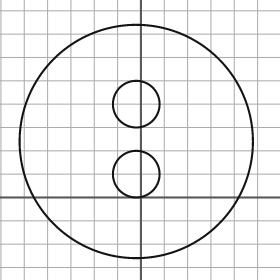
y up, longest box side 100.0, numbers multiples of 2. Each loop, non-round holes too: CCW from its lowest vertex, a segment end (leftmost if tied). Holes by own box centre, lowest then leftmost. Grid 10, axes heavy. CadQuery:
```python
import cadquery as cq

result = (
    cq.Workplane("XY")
    .moveTo(-2.0, 24.0)
    .circle(50.0)
    .moveTo(-2.0, 10.0)
    .circle(10.0)
    .moveTo(-2.0, 40.0)
    .circle(10.0)
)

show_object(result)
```